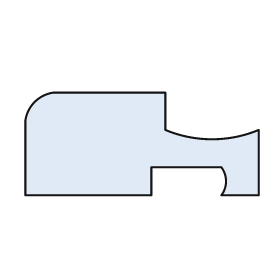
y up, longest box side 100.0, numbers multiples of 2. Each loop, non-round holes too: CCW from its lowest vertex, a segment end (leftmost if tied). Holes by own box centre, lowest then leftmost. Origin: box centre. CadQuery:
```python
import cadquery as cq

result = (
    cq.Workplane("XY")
    .moveTo(-50.0, -22.0)
    .lineTo(4.0, -22.0)
    .lineTo(4.0, -10.0)
    .lineTo(34.0, -10.0)
    .threePointArc((36.0, -16.0), (34.0, -22.0))
    .lineTo(50.0, -22.0)
    .lineTo(50.0, 6.0)
    .threePointArc((30.0, 2.0), (10.0, 6.0))
    .lineTo(10.0, 22.0)
    .lineTo(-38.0, 22.0)
    .threePointArc((-46.0, 18.0), (-50.0, 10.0))
    .close()
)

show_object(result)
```